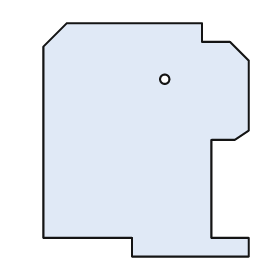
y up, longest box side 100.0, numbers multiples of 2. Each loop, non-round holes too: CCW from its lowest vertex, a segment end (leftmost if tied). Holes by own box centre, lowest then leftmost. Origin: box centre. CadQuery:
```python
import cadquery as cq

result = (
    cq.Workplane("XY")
    .moveTo(-6.0, -50.0)
    .lineTo(44.0, -50.0)
    .lineTo(44.0, -42.0)
    .lineTo(28.0, -42.0)
    .lineTo(28.0, 0.0)
    .lineTo(38.0, 0.0)
    .lineTo(44.0, 4.0)
    .lineTo(44.0, 34.0)
    .lineTo(36.0, 42.0)
    .lineTo(24.0, 42.0)
    .lineTo(24.0, 50.0)
    .lineTo(-34.0, 50.0)
    .lineTo(-44.0, 40.0)
    .lineTo(-44.0, -42.0)
    .lineTo(-6.0, -42.0)
    .close()
    .moveTo(8.0, 26.0)
    .circle(2.0)
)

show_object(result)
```